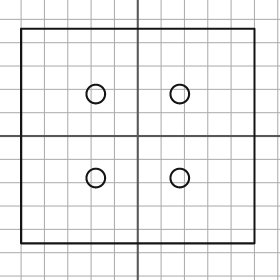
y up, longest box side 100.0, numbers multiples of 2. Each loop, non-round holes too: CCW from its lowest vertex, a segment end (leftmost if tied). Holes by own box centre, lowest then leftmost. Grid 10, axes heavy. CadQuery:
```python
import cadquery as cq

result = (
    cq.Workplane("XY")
    .moveTo(-50.0, -46.0)
    .lineTo(50.0, -46.0)
    .lineTo(50.0, 46.0)
    .lineTo(-50.0, 46.0)
    .close()
    .moveTo(-18.0, -18.0)
    .circle(4.0)
    .moveTo(18.0, -18.0)
    .circle(4.0)
    .moveTo(-18.0, 18.0)
    .circle(4.0)
    .moveTo(18.0, 18.0)
    .circle(4.0)
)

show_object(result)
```